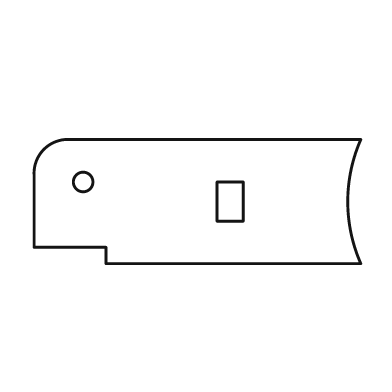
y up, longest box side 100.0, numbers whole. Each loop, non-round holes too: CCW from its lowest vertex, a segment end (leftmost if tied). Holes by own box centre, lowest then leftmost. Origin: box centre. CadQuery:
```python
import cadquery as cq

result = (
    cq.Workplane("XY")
    .moveTo(-28.0, -19.0)
    .lineTo(50.0, -19.0)
    .threePointArc((46.0, 0.0), (50.0, 19.0))
    .lineTo(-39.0, 19.0)
    .threePointArc((-47.0, 16.0), (-50.0, 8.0))
    .lineTo(-50.0, -14.0)
    .lineTo(-28.0, -14.0)
    .close()
    .moveTo(6.0, -6.0)
    .lineTo(14.0, -6.0)
    .lineTo(14.0, 6.0)
    .lineTo(6.0, 6.0)
    .close()
    .moveTo(-35.0, 6.0)
    .circle(3.0)
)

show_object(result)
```